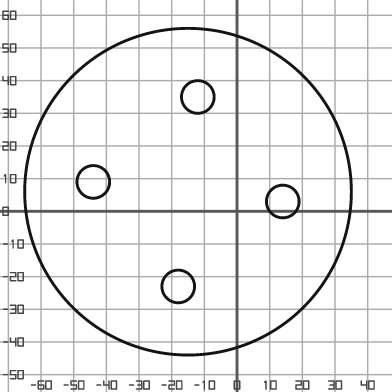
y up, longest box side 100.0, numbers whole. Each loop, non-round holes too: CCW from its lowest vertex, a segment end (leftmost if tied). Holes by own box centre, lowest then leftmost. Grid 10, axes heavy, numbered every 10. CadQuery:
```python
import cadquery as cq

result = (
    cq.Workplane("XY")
    .moveTo(-15.0, 6.0)
    .circle(50.0)
    .moveTo(-18.0, -23.0)
    .circle(5.0)
    .moveTo(14.0, 3.0)
    .circle(5.0)
    .moveTo(-44.0, 9.0)
    .circle(5.0)
    .moveTo(-12.0, 35.0)
    .circle(5.0)
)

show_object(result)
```